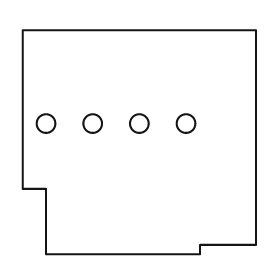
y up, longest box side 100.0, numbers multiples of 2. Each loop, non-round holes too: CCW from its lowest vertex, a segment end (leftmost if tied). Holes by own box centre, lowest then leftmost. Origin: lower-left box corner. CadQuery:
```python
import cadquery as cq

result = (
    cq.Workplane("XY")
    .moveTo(10.0, 0.0)
    .lineTo(76.0, 0.0)
    .lineTo(76.0, 4.0)
    .lineTo(100.0, 4.0)
    .lineTo(100.0, 96.0)
    .lineTo(0.0, 96.0)
    .lineTo(0.0, 28.0)
    .lineTo(10.0, 28.0)
    .close()
    .moveTo(10.0, 56.0)
    .circle(4.0)
    .moveTo(30.0, 56.0)
    .circle(4.0)
    .moveTo(50.0, 56.0)
    .circle(4.0)
    .moveTo(70.0, 56.0)
    .circle(4.0)
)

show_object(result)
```